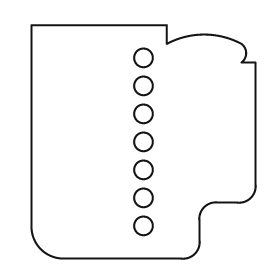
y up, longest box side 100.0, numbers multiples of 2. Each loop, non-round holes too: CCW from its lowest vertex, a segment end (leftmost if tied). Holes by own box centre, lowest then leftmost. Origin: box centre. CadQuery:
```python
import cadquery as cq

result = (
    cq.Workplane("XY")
    .moveTo(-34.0, -50.0)
    .lineTo(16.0, -50.0)
    .threePointArc((22.0, -48.0), (24.0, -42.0))
    .lineTo(24.0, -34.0)
    .threePointArc((26.0, -28.0), (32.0, -26.0))
    .lineTo(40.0, -26.0)
    .threePointArc((46.0, -24.0), (48.0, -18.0))
    .lineTo(48.0, 34.0)
    .lineTo(42.0, 34.0)
    .threePointArc((44.0, 38.0), (42.0, 42.0))
    .threePointArc((26.0, 46.0), (10.0, 42.0))
    .lineTo(10.0, 50.0)
    .lineTo(-48.0, 50.0)
    .lineTo(-48.0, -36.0)
    .threePointArc((-44.0, -46.0), (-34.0, -50.0))
    .close()
    .moveTo(0.0, -36.0)
    .circle(4.0)
    .moveTo(0.0, -24.0)
    .circle(4.0)
    .moveTo(0.0, -12.0)
    .circle(4.0)
    .moveTo(0.0, 0.0)
    .circle(4.0)
    .moveTo(0.0, 12.0)
    .circle(4.0)
    .moveTo(0.0, 24.0)
    .circle(4.0)
    .moveTo(0.0, 36.0)
    .circle(4.0)
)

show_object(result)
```